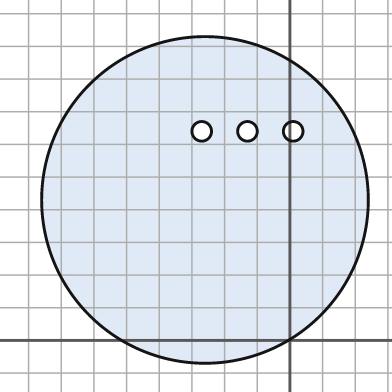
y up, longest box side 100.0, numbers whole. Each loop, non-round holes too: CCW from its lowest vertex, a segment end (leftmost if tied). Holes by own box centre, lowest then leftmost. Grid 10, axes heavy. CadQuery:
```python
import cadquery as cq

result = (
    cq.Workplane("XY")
    .moveTo(-26.0, 43.0)
    .circle(50.0)
    .moveTo(-27.0, 64.0)
    .circle(3.0)
    .moveTo(-13.0, 64.0)
    .circle(3.0)
    .moveTo(1.0, 64.0)
    .circle(3.0)
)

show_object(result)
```